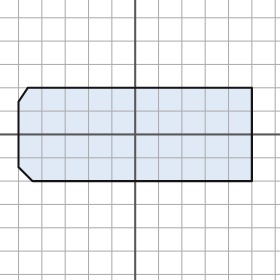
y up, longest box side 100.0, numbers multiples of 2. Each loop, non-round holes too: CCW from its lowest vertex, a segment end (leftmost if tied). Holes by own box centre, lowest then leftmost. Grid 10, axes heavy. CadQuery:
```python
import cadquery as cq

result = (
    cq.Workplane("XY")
    .moveTo(-44.0, -20.0)
    .lineTo(50.0, -20.0)
    .lineTo(50.0, 20.0)
    .lineTo(-46.0, 20.0)
    .lineTo(-50.0, 14.0)
    .lineTo(-50.0, -14.0)
    .close()
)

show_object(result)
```